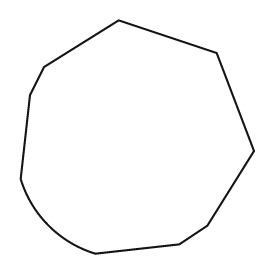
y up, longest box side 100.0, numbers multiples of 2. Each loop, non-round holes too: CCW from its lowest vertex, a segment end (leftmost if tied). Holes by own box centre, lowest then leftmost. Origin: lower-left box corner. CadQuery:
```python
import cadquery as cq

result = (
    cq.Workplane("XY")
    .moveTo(32.0, 0.0)
    .lineTo(68.0, 4.0)
    .lineTo(80.0, 12.0)
    .lineTo(100.0, 44.0)
    .lineTo(84.0, 86.0)
    .lineTo(42.0, 100.0)
    .lineTo(10.0, 80.0)
    .lineTo(4.0, 68.0)
    .lineTo(0.0, 32.0)
    .threePointArc((12.0, 12.0), (32.0, 0.0))
    .close()
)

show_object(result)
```